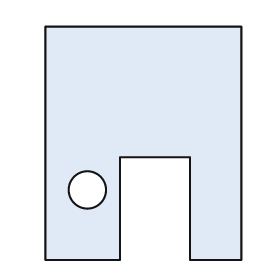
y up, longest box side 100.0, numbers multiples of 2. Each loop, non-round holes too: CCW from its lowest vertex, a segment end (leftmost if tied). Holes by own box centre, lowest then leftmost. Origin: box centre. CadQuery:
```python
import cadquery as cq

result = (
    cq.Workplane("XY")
    .moveTo(-42.0, -50.0)
    .lineTo(-10.0, -50.0)
    .lineTo(-10.0, -6.0)
    .lineTo(20.0, -6.0)
    .lineTo(20.0, -50.0)
    .lineTo(42.0, -50.0)
    .lineTo(42.0, 50.0)
    .lineTo(-42.0, 50.0)
    .close()
    .moveTo(-24.0, -20.0)
    .circle(8.0)
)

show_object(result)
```